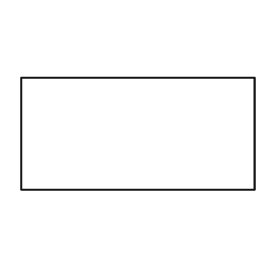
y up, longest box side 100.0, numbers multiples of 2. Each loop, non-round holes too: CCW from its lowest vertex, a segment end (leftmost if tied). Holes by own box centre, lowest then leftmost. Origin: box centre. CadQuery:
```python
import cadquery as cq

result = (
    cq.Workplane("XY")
    .moveTo(-50.0, -24.0)
    .lineTo(50.0, -24.0)
    .lineTo(50.0, 24.0)
    .lineTo(-50.0, 24.0)
    .close()
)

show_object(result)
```